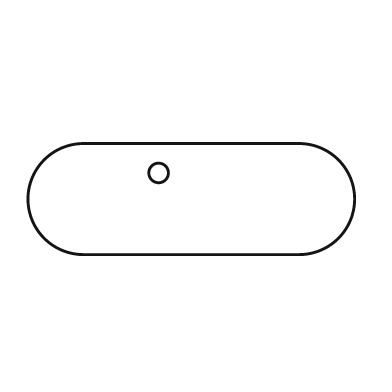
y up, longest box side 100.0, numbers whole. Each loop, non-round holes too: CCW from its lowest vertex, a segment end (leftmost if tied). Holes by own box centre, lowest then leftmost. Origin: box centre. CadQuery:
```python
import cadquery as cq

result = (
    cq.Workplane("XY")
    .moveTo(-33.0, -17.0)
    .lineTo(33.0, -17.0)
    .threePointArc((50.0, 0.0), (33.0, 17.0))
    .lineTo(-33.0, 17.0)
    .threePointArc((-50.0, 0.0), (-33.0, -17.0))
    .close()
    .moveTo(-10.0, 8.0)
    .circle(3.0)
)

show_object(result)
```